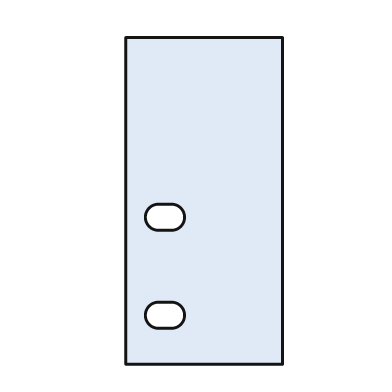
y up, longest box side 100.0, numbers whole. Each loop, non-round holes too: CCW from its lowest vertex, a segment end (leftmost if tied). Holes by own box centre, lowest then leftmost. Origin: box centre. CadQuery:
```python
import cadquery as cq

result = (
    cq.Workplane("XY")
    .moveTo(-24.0, -50.0)
    .lineTo(24.0, -50.0)
    .lineTo(24.0, 50.0)
    .lineTo(-24.0, 50.0)
    .close()
    .moveTo(-14.0, -39.0)
    .lineTo(-10.0, -39.0)
    .threePointArc((-6.0, -35.0), (-10.0, -31.0))
    .lineTo(-14.0, -31.0)
    .threePointArc((-18.0, -35.0), (-14.0, -39.0))
    .close()
    .moveTo(-14.0, -9.0)
    .lineTo(-10.0, -9.0)
    .threePointArc((-6.0, -5.0), (-10.0, -1.0))
    .lineTo(-14.0, -1.0)
    .threePointArc((-18.0, -5.0), (-14.0, -9.0))
    .close()
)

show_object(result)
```